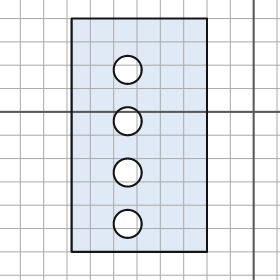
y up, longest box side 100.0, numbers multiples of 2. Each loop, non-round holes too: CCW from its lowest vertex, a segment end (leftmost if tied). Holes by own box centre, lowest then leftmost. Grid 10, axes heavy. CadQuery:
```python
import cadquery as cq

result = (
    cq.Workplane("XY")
    .moveTo(-78.0, -60.0)
    .lineTo(-20.0, -60.0)
    .lineTo(-20.0, 40.0)
    .lineTo(-78.0, 40.0)
    .close()
    .moveTo(-54.0, -48.0)
    .circle(6.0)
    .moveTo(-54.0, -26.0)
    .circle(6.0)
    .moveTo(-54.0, -4.0)
    .circle(6.0)
    .moveTo(-54.0, 18.0)
    .circle(6.0)
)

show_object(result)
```